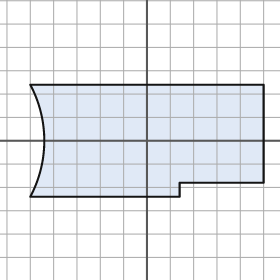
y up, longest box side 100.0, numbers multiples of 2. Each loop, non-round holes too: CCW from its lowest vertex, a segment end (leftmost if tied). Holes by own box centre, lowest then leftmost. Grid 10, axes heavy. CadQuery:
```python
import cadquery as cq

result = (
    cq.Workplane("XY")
    .moveTo(-50.0, -24.0)
    .lineTo(14.0, -24.0)
    .lineTo(14.0, -18.0)
    .lineTo(50.0, -18.0)
    .lineTo(50.0, 24.0)
    .lineTo(-50.0, 24.0)
    .threePointArc((-44.0, 0.0), (-50.0, -24.0))
    .close()
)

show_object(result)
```